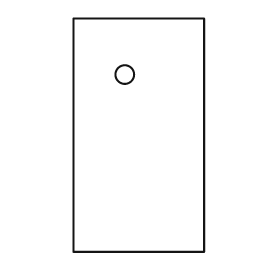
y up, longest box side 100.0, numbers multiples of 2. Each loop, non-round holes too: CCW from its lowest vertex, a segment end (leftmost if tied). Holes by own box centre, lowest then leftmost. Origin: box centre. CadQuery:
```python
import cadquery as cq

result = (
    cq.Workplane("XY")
    .moveTo(-28.0, -50.0)
    .lineTo(28.0, -50.0)
    .lineTo(28.0, 50.0)
    .lineTo(-28.0, 50.0)
    .close()
    .moveTo(-6.0, 26.0)
    .circle(4.0)
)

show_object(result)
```